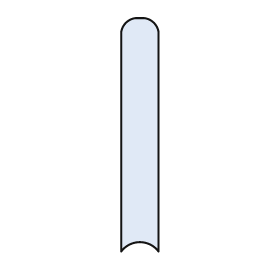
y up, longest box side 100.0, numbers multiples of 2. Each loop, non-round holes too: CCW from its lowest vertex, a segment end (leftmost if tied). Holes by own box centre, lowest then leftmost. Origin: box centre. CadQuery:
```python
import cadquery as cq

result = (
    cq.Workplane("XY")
    .moveTo(-8.0, -50.0)
    .threePointArc((0.0, -46.0), (8.0, -50.0))
    .lineTo(8.0, 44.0)
    .threePointArc((6.0, 48.0), (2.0, 50.0))
    .lineTo(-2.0, 50.0)
    .threePointArc((-6.0, 48.0), (-8.0, 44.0))
    .close()
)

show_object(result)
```